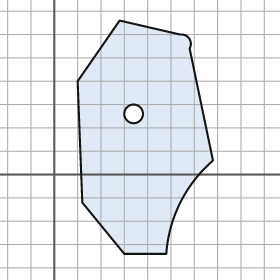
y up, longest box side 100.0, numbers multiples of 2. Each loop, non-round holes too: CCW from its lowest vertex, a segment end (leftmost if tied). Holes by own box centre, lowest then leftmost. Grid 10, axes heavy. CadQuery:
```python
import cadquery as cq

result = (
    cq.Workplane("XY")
    .moveTo(30.0, -34.0)
    .lineTo(48.0, -34.0)
    .threePointArc((54.0, -12.0), (68.0, 6.0))
    .lineTo(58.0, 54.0)
    .threePointArc((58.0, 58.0), (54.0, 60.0))
    .lineTo(28.0, 66.0)
    .lineTo(10.0, 40.0)
    .lineTo(12.0, -12.0)
    .close()
    .moveTo(34.0, 26.0)
    .circle(4.0)
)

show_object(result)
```